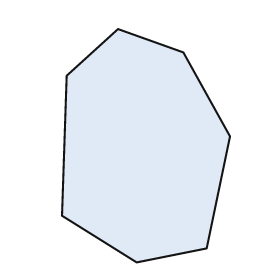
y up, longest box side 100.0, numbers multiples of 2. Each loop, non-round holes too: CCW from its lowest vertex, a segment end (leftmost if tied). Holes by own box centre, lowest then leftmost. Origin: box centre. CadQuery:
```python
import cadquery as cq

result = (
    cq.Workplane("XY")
    .moveTo(-4.0, -50.0)
    .lineTo(26.0, -44.0)
    .lineTo(36.0, 4.0)
    .lineTo(16.0, 40.0)
    .lineTo(-12.0, 50.0)
    .lineTo(-34.0, 30.0)
    .lineTo(-36.0, -30.0)
    .close()
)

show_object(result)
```